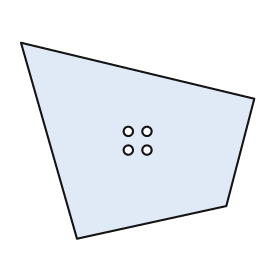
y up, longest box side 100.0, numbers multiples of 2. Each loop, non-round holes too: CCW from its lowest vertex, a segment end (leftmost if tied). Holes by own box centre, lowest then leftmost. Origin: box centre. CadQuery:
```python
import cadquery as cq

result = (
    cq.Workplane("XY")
    .moveTo(-26.0, -42.0)
    .lineTo(38.0, -28.0)
    .lineTo(50.0, 18.0)
    .lineTo(-50.0, 42.0)
    .close()
    .moveTo(-4.0, -4.0)
    .circle(2.0)
    .moveTo(4.0, -4.0)
    .circle(2.0)
    .moveTo(-4.0, 4.0)
    .circle(2.0)
    .moveTo(4.0, 4.0)
    .circle(2.0)
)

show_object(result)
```